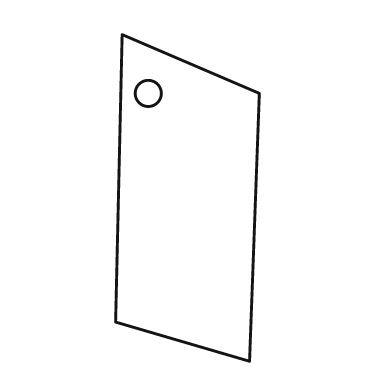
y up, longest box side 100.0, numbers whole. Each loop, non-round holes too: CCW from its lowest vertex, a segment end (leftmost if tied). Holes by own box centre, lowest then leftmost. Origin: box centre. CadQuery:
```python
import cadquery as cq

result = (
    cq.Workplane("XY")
    .moveTo(19.0, -50.0)
    .lineTo(22.0, 32.0)
    .lineTo(-20.0, 50.0)
    .lineTo(-22.0, -38.0)
    .close()
    .moveTo(-12.0, 32.0)
    .circle(4.0)
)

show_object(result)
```